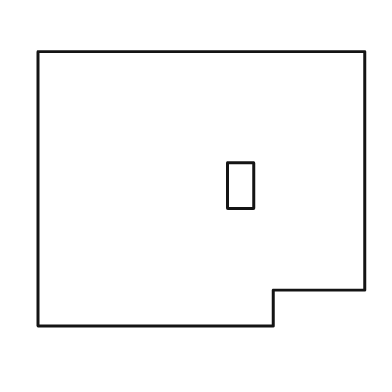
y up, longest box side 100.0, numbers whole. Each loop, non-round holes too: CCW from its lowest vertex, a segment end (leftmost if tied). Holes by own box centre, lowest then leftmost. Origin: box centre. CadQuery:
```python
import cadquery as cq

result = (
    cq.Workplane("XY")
    .moveTo(-50.0, -42.0)
    .lineTo(22.0, -42.0)
    .lineTo(22.0, -31.0)
    .lineTo(50.0, -31.0)
    .lineTo(50.0, 42.0)
    .lineTo(-50.0, 42.0)
    .close()
    .moveTo(8.0, -6.0)
    .lineTo(16.0, -6.0)
    .lineTo(16.0, 8.0)
    .lineTo(8.0, 8.0)
    .close()
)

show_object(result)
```